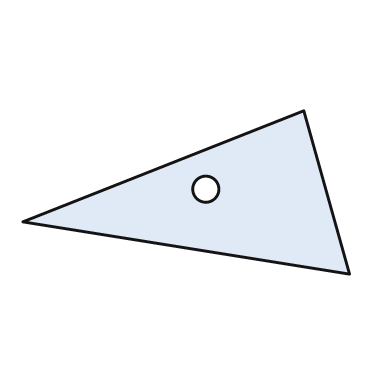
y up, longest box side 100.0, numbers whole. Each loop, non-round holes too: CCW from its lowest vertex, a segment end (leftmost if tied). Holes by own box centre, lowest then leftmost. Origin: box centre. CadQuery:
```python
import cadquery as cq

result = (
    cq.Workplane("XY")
    .moveTo(50.0, -25.0)
    .lineTo(36.0, 25.0)
    .lineTo(-50.0, -9.0)
    .close()
    .moveTo(6.0, 1.0)
    .circle(4.0)
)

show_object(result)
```